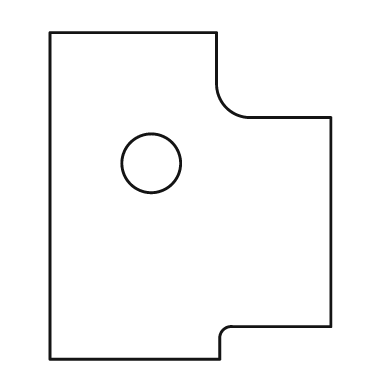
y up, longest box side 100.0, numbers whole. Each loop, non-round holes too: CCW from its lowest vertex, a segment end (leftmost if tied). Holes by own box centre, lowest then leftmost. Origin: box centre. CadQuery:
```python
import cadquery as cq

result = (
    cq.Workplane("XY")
    .moveTo(-43.0, -50.0)
    .lineTo(9.0, -50.0)
    .lineTo(9.0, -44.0)
    .threePointArc((10.0, -41.0), (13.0, -40.0))
    .lineTo(43.0, -40.0)
    .lineTo(43.0, 24.0)
    .lineTo(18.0, 24.0)
    .threePointArc((11.0, 27.0), (8.0, 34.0))
    .lineTo(8.0, 50.0)
    .lineTo(-43.0, 50.0)
    .close()
    .moveTo(-12.0, 10.0)
    .circle(9.0)
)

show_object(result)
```